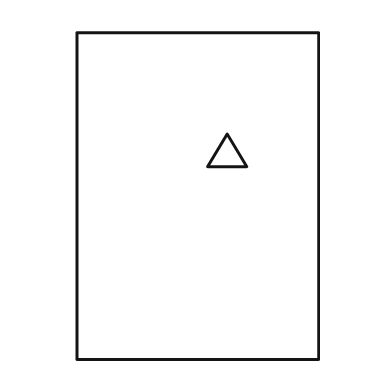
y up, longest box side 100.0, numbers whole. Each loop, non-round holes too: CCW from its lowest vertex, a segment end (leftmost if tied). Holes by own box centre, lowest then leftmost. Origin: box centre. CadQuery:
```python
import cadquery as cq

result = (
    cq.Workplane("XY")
    .moveTo(-37.0, -50.0)
    .lineTo(37.0, -50.0)
    .lineTo(37.0, 50.0)
    .lineTo(-37.0, 50.0)
    .close()
    .moveTo(3.0, 9.0)
    .lineTo(15.0, 9.0)
    .lineTo(9.0, 19.0)
    .close()
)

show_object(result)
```